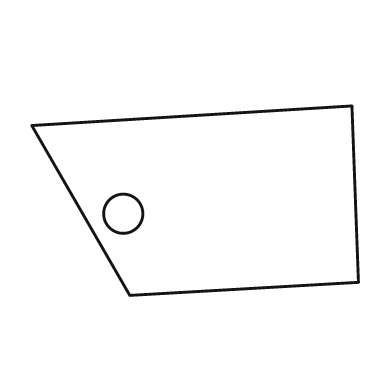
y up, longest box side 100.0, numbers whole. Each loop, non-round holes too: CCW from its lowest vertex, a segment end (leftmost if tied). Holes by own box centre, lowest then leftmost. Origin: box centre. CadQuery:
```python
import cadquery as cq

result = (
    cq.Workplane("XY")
    .moveTo(-20.0, -29.0)
    .lineTo(50.0, -25.0)
    .lineTo(48.0, 29.0)
    .lineTo(-50.0, 23.0)
    .close()
    .moveTo(-22.0, -4.0)
    .circle(6.0)
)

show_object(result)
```